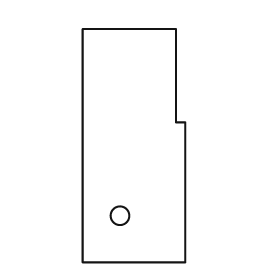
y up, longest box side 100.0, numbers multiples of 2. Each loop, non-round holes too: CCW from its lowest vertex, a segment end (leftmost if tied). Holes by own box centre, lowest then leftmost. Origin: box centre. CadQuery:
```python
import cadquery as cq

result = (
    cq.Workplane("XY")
    .moveTo(-22.0, -50.0)
    .lineTo(22.0, -50.0)
    .lineTo(22.0, 10.0)
    .lineTo(18.0, 10.0)
    .lineTo(18.0, 50.0)
    .lineTo(-22.0, 50.0)
    .close()
    .moveTo(-6.0, -30.0)
    .circle(4.0)
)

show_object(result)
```